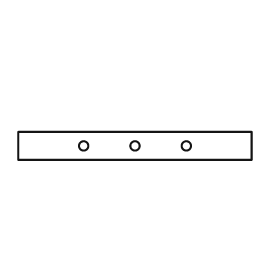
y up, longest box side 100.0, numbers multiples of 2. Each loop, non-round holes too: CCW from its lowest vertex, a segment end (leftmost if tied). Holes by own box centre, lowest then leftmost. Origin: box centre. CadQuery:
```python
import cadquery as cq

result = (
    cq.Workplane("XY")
    .moveTo(-50.0, -6.0)
    .lineTo(50.0, -6.0)
    .lineTo(50.0, 6.0)
    .lineTo(-50.0, 6.0)
    .close()
    .moveTo(-22.0, 0.0)
    .circle(2.0)
    .moveTo(0.0, 0.0)
    .circle(2.0)
    .moveTo(22.0, 0.0)
    .circle(2.0)
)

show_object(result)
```